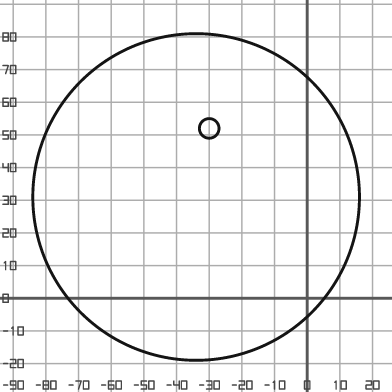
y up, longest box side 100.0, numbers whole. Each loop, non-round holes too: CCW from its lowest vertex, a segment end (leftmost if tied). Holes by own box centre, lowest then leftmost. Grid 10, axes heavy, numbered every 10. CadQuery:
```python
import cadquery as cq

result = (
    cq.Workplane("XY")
    .moveTo(-34.0, 31.0)
    .circle(50.0)
    .moveTo(-30.0, 52.0)
    .circle(3.0)
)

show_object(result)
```